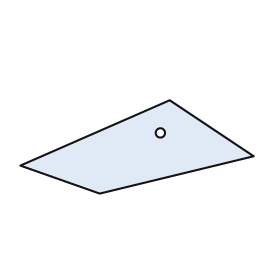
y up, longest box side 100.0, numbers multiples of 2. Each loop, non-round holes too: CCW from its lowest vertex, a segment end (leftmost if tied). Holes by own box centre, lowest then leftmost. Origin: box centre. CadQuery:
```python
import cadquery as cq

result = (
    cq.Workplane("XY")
    .moveTo(-16.0, -20.0)
    .lineTo(50.0, -4.0)
    .lineTo(14.0, 20.0)
    .lineTo(-50.0, -8.0)
    .close()
    .moveTo(10.0, 6.0)
    .circle(2.0)
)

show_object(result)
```